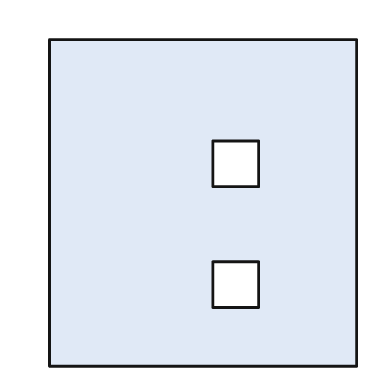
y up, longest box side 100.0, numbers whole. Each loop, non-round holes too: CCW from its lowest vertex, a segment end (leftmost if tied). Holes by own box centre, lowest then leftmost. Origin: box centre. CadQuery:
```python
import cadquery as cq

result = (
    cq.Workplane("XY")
    .moveTo(-47.0, -50.0)
    .lineTo(47.0, -50.0)
    .lineTo(47.0, 50.0)
    .lineTo(-47.0, 50.0)
    .close()
    .moveTo(3.0, -32.0)
    .lineTo(17.0, -32.0)
    .lineTo(17.0, -18.0)
    .lineTo(3.0, -18.0)
    .close()
    .moveTo(3.0, 5.0)
    .lineTo(17.0, 5.0)
    .lineTo(17.0, 19.0)
    .lineTo(3.0, 19.0)
    .close()
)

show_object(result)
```